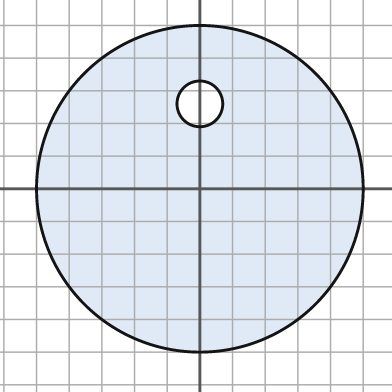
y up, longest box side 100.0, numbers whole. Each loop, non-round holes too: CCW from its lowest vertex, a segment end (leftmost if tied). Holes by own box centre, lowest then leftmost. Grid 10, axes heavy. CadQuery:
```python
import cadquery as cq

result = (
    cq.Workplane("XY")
    .moveTo(0.0, 0.0)
    .circle(50.0)
    .moveTo(0.0, 26.0)
    .circle(7.0)
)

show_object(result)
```